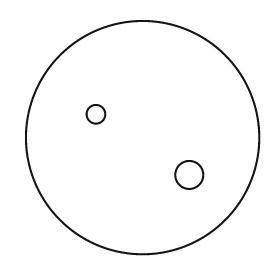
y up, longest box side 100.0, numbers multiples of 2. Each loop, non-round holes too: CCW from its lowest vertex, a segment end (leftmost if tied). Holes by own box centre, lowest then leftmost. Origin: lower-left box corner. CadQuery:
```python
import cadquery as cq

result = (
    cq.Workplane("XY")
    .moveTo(50.0, 50.0)
    .circle(50.0)
    .moveTo(70.0, 34.0)
    .circle(6.0)
    .moveTo(30.0, 60.0)
    .circle(4.0)
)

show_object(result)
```